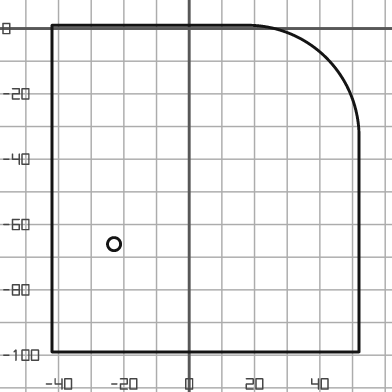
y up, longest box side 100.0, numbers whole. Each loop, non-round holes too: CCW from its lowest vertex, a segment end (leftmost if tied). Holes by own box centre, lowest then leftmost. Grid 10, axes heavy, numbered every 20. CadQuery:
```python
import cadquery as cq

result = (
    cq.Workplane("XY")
    .moveTo(-42.0, -99.0)
    .lineTo(52.0, -99.0)
    .lineTo(52.0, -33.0)
    .threePointArc((42.0, -9.0), (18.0, 1.0))
    .lineTo(-42.0, 1.0)
    .close()
    .moveTo(-23.0, -66.0)
    .circle(2.0)
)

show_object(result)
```